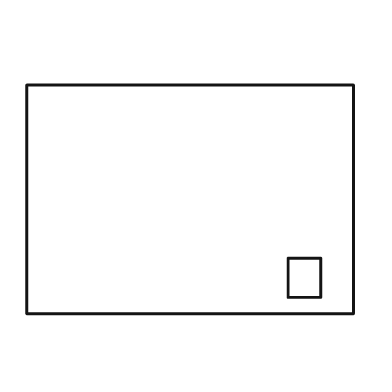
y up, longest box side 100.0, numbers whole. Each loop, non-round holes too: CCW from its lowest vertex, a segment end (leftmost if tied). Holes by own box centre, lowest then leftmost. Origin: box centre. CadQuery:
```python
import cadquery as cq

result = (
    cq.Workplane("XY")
    .moveTo(-50.0, -35.0)
    .lineTo(50.0, -35.0)
    .lineTo(50.0, 35.0)
    .lineTo(-50.0, 35.0)
    .close()
    .moveTo(30.0, -30.0)
    .lineTo(40.0, -30.0)
    .lineTo(40.0, -18.0)
    .lineTo(30.0, -18.0)
    .close()
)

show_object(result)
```